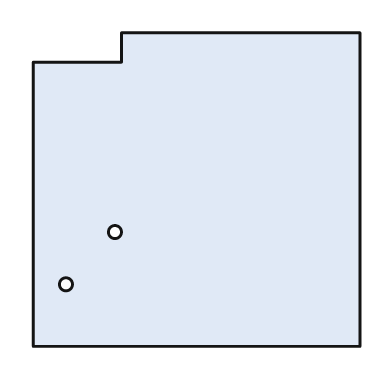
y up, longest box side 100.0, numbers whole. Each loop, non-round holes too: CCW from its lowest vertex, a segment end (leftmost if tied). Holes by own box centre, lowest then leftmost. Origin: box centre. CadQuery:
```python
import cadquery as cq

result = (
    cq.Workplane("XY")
    .moveTo(-50.0, -48.0)
    .lineTo(50.0, -48.0)
    .lineTo(50.0, 48.0)
    .lineTo(-23.0, 48.0)
    .lineTo(-23.0, 39.0)
    .lineTo(-50.0, 39.0)
    .close()
    .moveTo(-40.0, -29.0)
    .circle(2.0)
    .moveTo(-25.0, -13.0)
    .circle(2.0)
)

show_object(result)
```